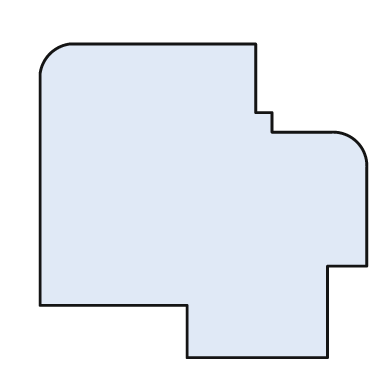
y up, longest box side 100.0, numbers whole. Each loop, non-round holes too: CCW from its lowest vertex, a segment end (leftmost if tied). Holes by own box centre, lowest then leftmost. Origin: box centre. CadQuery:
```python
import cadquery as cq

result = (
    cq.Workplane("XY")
    .moveTo(-5.0, -48.0)
    .lineTo(38.0, -48.0)
    .lineTo(38.0, -20.0)
    .lineTo(50.0, -20.0)
    .lineTo(50.0, 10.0)
    .threePointArc((47.0, 18.0), (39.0, 21.0))
    .lineTo(21.0, 21.0)
    .lineTo(21.0, 27.0)
    .lineTo(16.0, 27.0)
    .lineTo(16.0, 48.0)
    .lineTo(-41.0, 48.0)
    .threePointArc((-47.0, 45.0), (-50.0, 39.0))
    .lineTo(-50.0, -32.0)
    .lineTo(-5.0, -32.0)
    .close()
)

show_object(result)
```